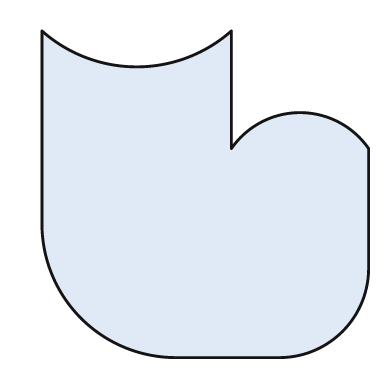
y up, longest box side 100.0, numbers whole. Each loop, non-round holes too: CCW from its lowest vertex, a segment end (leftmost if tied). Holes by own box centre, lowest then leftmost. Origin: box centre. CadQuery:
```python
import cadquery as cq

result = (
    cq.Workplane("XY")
    .moveTo(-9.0, -50.0)
    .lineTo(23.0, -50.0)
    .threePointArc((42.0, -42.0), (50.0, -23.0))
    .lineTo(50.0, 14.0)
    .threePointArc((29.0, 25.0), (8.0, 14.0))
    .lineTo(8.0, 50.0)
    .threePointArc((-21.0, 39.0), (-50.0, 50.0))
    .lineTo(-50.0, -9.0)
    .threePointArc((-38.0, -38.0), (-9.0, -50.0))
    .close()
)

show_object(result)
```